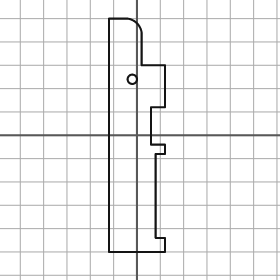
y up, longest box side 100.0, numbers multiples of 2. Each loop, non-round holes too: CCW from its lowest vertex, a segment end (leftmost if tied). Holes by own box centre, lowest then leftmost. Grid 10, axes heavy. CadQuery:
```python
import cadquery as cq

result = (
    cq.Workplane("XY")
    .moveTo(-12.0, -50.0)
    .lineTo(12.0, -50.0)
    .lineTo(12.0, -44.0)
    .lineTo(8.0, -44.0)
    .lineTo(8.0, -8.0)
    .lineTo(12.0, -8.0)
    .lineTo(12.0, -4.0)
    .lineTo(6.0, -4.0)
    .lineTo(6.0, 12.0)
    .lineTo(12.0, 12.0)
    .lineTo(12.0, 30.0)
    .lineTo(2.0, 30.0)
    .lineTo(2.0, 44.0)
    .threePointArc((0.0, 48.0), (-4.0, 50.0))
    .lineTo(-12.0, 50.0)
    .close()
    .moveTo(-2.0, 24.0)
    .circle(2.0)
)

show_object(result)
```